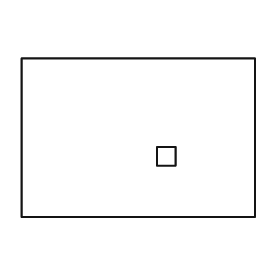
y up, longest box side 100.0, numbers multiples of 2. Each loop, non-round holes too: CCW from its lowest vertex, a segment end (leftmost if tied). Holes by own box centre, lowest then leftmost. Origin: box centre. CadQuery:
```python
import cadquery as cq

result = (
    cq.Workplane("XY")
    .moveTo(-50.0, -34.0)
    .lineTo(50.0, -34.0)
    .lineTo(50.0, 34.0)
    .lineTo(-50.0, 34.0)
    .close()
    .moveTo(8.0, -12.0)
    .lineTo(16.0, -12.0)
    .lineTo(16.0, -4.0)
    .lineTo(8.0, -4.0)
    .close()
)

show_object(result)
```